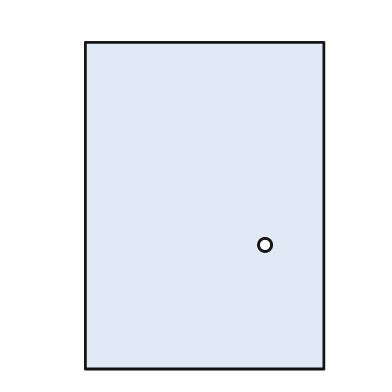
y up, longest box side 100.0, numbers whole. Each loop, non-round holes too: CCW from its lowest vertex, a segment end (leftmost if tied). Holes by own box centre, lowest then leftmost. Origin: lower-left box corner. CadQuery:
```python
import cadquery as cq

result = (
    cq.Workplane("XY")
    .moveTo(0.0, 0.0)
    .lineTo(73.0, 0.0)
    .lineTo(73.0, 100.0)
    .lineTo(0.0, 100.0)
    .close()
    .moveTo(55.0, 38.0)
    .circle(2.0)
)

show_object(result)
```